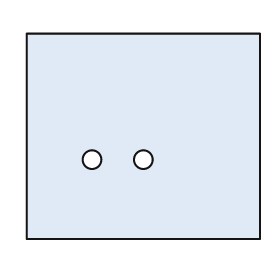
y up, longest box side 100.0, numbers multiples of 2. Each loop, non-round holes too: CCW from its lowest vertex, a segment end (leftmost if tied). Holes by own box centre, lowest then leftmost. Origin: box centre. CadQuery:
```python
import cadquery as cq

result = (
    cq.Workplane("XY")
    .moveTo(-50.0, -44.0)
    .lineTo(50.0, -44.0)
    .lineTo(50.0, 44.0)
    .lineTo(-50.0, 44.0)
    .close()
    .moveTo(-22.0, -10.0)
    .circle(4.0)
    .moveTo(0.0, -10.0)
    .circle(4.0)
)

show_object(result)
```